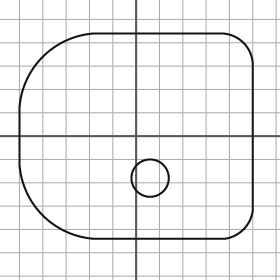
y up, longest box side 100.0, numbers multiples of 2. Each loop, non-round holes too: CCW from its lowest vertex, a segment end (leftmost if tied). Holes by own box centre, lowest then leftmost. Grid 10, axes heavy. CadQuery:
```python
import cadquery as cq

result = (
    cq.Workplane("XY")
    .moveTo(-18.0, -44.0)
    .lineTo(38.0, -44.0)
    .threePointArc((46.0, -40.0), (50.0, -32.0))
    .lineTo(50.0, 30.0)
    .threePointArc((46.0, 40.0), (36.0, 44.0))
    .lineTo(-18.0, 44.0)
    .threePointArc((-40.0, 34.0), (-50.0, 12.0))
    .lineTo(-50.0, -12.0)
    .threePointArc((-40.0, -34.0), (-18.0, -44.0))
    .close()
    .moveTo(6.0, -18.0)
    .circle(8.0)
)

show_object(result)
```